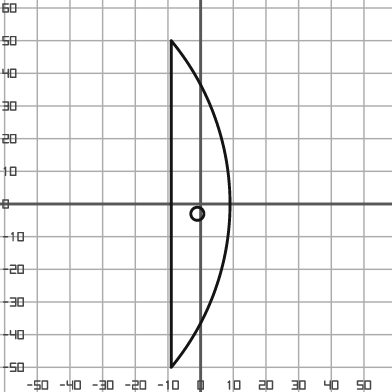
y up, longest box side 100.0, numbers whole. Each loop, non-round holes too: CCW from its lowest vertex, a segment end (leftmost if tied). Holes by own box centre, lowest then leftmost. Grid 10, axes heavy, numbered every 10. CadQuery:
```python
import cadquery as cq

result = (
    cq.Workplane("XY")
    .moveTo(-9.0, -50.0)
    .threePointArc((9.0, 0.0), (-9.0, 50.0))
    .close()
    .moveTo(-1.0, -3.0)
    .circle(2.0)
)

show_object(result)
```